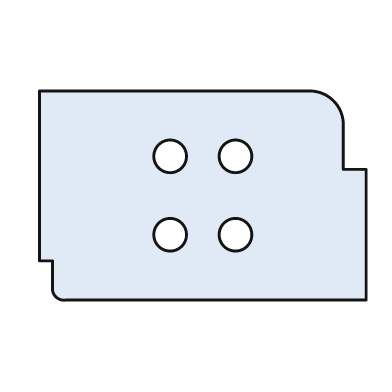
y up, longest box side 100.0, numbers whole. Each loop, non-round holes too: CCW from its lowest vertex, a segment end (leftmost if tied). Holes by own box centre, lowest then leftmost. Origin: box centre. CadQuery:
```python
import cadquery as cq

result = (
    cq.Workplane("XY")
    .moveTo(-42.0, -32.0)
    .lineTo(50.0, -32.0)
    .lineTo(50.0, 8.0)
    .lineTo(43.0, 8.0)
    .lineTo(43.0, 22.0)
    .threePointArc((40.0, 29.0), (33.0, 32.0))
    .lineTo(-50.0, 32.0)
    .lineTo(-50.0, -20.0)
    .lineTo(-46.0, -20.0)
    .lineTo(-46.0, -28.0)
    .threePointArc((-45.0, -31.0), (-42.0, -32.0))
    .close()
    .moveTo(-10.0, -12.0)
    .circle(5.0)
    .moveTo(10.0, -12.0)
    .circle(5.0)
    .moveTo(-10.0, 12.0)
    .circle(5.0)
    .moveTo(10.0, 12.0)
    .circle(5.0)
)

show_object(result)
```